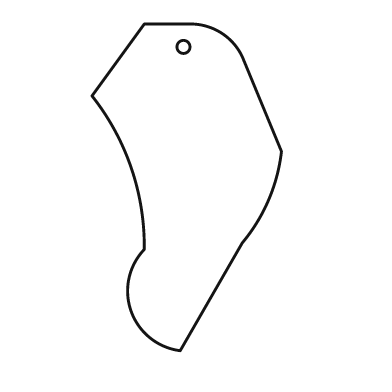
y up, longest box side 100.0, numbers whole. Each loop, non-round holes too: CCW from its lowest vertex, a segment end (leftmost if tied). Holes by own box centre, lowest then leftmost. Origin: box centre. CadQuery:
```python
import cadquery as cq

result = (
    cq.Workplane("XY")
    .moveTo(-2.0, -50.0)
    .lineTo(17.0, -17.0)
    .threePointArc((25.0, -4.0), (29.0, 11.0))
    .lineTo(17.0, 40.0)
    .threePointArc((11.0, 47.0), (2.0, 50.0))
    .lineTo(-13.0, 50.0)
    .lineTo(-29.0, 28.0)
    .threePointArc((-17.0, 6.0), (-13.0, -19.0))
    .threePointArc((-17.0, -38.0), (-2.0, -50.0))
    .close()
    .moveTo(-1.0, 43.0)
    .circle(2.0)
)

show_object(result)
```